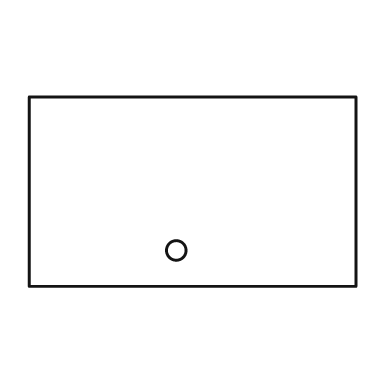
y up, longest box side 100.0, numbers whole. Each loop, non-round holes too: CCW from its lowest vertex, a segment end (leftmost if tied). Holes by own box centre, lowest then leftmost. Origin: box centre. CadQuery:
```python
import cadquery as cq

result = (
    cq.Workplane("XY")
    .moveTo(-50.0, -29.0)
    .lineTo(50.0, -29.0)
    .lineTo(50.0, 29.0)
    .lineTo(-50.0, 29.0)
    .close()
    .moveTo(-5.0, -18.0)
    .circle(3.0)
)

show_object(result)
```